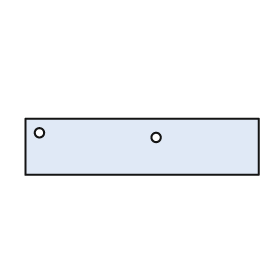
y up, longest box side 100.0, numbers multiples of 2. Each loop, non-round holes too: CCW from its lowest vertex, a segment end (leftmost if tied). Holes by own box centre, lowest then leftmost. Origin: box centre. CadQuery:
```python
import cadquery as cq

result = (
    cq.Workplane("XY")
    .moveTo(-50.0, -12.0)
    .lineTo(50.0, -12.0)
    .lineTo(50.0, 12.0)
    .lineTo(-50.0, 12.0)
    .close()
    .moveTo(6.0, 4.0)
    .circle(2.0)
    .moveTo(-44.0, 6.0)
    .circle(2.0)
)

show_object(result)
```